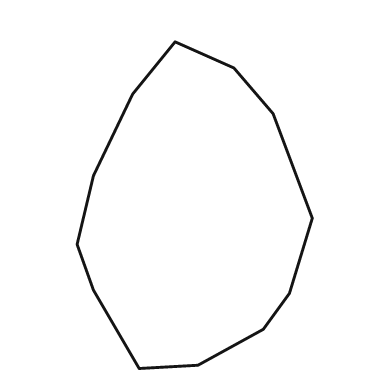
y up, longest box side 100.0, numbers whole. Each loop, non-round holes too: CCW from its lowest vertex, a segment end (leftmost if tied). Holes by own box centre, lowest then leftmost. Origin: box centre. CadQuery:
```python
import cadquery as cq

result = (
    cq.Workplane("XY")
    .moveTo(-17.0, -50.0)
    .lineTo(1.0, -49.0)
    .lineTo(21.0, -38.0)
    .lineTo(29.0, -27.0)
    .lineTo(36.0, -4.0)
    .lineTo(24.0, 28.0)
    .lineTo(12.0, 42.0)
    .lineTo(-6.0, 50.0)
    .lineTo(-19.0, 34.0)
    .lineTo(-31.0, 9.0)
    .lineTo(-36.0, -12.0)
    .lineTo(-31.0, -26.0)
    .close()
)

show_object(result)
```